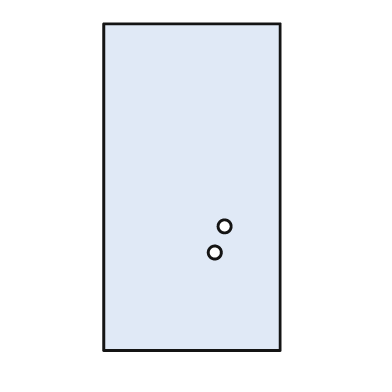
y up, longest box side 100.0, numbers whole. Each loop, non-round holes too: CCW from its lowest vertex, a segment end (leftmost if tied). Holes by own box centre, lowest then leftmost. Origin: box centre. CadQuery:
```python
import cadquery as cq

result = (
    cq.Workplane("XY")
    .moveTo(-27.0, -50.0)
    .lineTo(27.0, -50.0)
    .lineTo(27.0, 50.0)
    .lineTo(-27.0, 50.0)
    .close()
    .moveTo(7.0, -20.0)
    .circle(2.0)
    .moveTo(10.0, -12.0)
    .circle(2.0)
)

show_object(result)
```